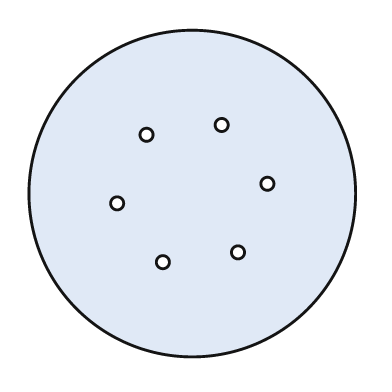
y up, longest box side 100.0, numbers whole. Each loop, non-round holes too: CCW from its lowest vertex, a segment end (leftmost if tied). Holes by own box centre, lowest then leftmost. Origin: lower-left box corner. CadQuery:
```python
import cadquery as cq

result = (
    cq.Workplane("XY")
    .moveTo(50.0, 50.0)
    .circle(50.0)
    .moveTo(41.0, 29.0)
    .circle(2.0)
    .moveTo(64.0, 32.0)
    .circle(2.0)
    .moveTo(27.0, 47.0)
    .circle(2.0)
    .moveTo(73.0, 53.0)
    .circle(2.0)
    .moveTo(36.0, 68.0)
    .circle(2.0)
    .moveTo(59.0, 71.0)
    .circle(2.0)
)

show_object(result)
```